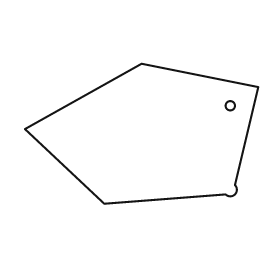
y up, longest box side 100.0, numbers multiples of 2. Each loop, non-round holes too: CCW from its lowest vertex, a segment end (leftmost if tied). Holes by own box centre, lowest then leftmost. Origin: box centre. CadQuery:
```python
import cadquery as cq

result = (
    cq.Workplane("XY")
    .moveTo(-16.0, -30.0)
    .lineTo(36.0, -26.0)
    .threePointArc((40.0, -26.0), (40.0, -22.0))
    .lineTo(50.0, 20.0)
    .lineTo(0.0, 30.0)
    .lineTo(-50.0, 2.0)
    .close()
    .moveTo(38.0, 12.0)
    .circle(2.0)
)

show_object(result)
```